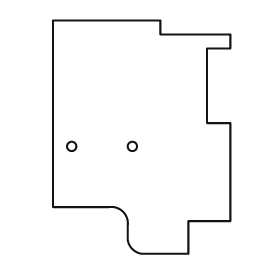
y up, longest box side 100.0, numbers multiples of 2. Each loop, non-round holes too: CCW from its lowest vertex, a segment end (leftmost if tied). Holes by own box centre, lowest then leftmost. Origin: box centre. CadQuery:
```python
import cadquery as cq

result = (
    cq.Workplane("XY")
    .moveTo(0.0, -50.0)
    .lineTo(20.0, -50.0)
    .lineTo(20.0, -36.0)
    .lineTo(38.0, -36.0)
    .lineTo(38.0, 6.0)
    .lineTo(28.0, 6.0)
    .lineTo(28.0, 38.0)
    .lineTo(38.0, 38.0)
    .lineTo(38.0, 44.0)
    .lineTo(8.0, 44.0)
    .lineTo(8.0, 50.0)
    .lineTo(-38.0, 50.0)
    .lineTo(-38.0, -30.0)
    .lineTo(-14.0, -30.0)
    .threePointArc((-8.0, -32.0), (-6.0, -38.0))
    .lineTo(-6.0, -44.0)
    .threePointArc((-4.0, -48.0), (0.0, -50.0))
    .close()
    .moveTo(-30.0, -4.0)
    .circle(2.0)
    .moveTo(-4.0, -4.0)
    .circle(2.0)
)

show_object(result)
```